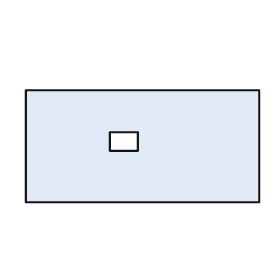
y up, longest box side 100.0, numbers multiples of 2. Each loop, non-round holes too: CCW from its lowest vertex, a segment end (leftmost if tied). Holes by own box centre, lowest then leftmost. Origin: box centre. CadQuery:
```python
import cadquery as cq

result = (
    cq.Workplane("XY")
    .moveTo(-50.0, -24.0)
    .lineTo(50.0, -24.0)
    .lineTo(50.0, 24.0)
    .lineTo(-50.0, 24.0)
    .close()
    .moveTo(-14.0, -2.0)
    .lineTo(-2.0, -2.0)
    .lineTo(-2.0, 6.0)
    .lineTo(-14.0, 6.0)
    .close()
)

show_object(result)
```